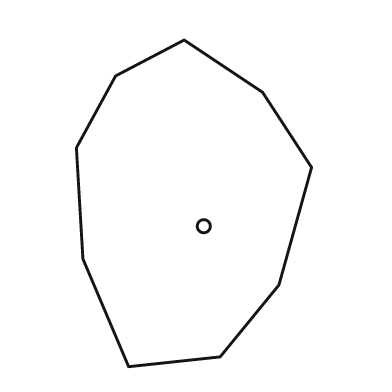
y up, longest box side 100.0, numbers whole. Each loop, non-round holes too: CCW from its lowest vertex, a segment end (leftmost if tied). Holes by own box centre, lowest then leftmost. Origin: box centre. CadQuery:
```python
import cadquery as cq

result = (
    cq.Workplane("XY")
    .moveTo(-20.0, -50.0)
    .lineTo(8.0, -47.0)
    .lineTo(26.0, -25.0)
    .lineTo(36.0, 11.0)
    .lineTo(21.0, 34.0)
    .lineTo(-3.0, 50.0)
    .lineTo(-24.0, 39.0)
    .lineTo(-36.0, 17.0)
    .lineTo(-34.0, -17.0)
    .close()
    .moveTo(3.0, -7.0)
    .circle(2.0)
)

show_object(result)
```